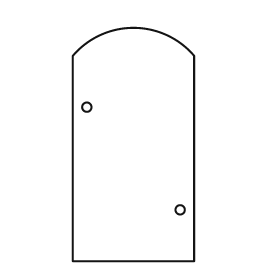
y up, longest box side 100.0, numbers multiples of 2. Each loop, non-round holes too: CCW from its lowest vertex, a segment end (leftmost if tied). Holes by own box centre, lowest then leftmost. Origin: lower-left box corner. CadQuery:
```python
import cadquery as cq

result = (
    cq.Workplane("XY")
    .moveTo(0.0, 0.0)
    .lineTo(52.0, 0.0)
    .lineTo(52.0, 88.0)
    .threePointArc((26.0, 100.0), (0.0, 88.0))
    .close()
    .moveTo(46.0, 22.0)
    .circle(2.0)
    .moveTo(6.0, 66.0)
    .circle(2.0)
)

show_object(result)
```